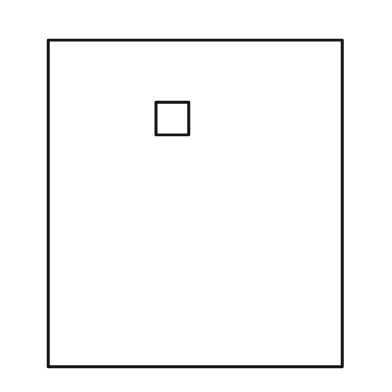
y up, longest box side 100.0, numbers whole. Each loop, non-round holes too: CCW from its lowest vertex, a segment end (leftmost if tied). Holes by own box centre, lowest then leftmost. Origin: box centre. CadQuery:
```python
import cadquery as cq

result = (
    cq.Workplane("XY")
    .moveTo(-45.0, -50.0)
    .lineTo(45.0, -50.0)
    .lineTo(45.0, 50.0)
    .lineTo(-45.0, 50.0)
    .close()
    .moveTo(-12.0, 21.0)
    .lineTo(-2.0, 21.0)
    .lineTo(-2.0, 31.0)
    .lineTo(-12.0, 31.0)
    .close()
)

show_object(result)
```